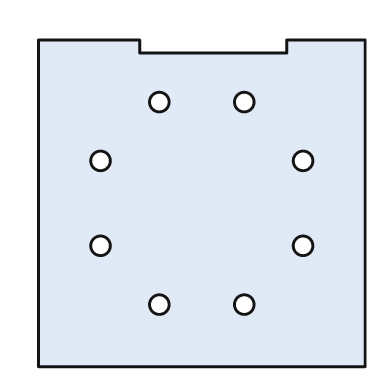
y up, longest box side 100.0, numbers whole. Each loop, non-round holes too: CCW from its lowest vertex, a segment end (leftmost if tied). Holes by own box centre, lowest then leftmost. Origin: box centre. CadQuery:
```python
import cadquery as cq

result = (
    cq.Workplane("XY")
    .moveTo(-50.0, -50.0)
    .lineTo(50.0, -50.0)
    .lineTo(50.0, 50.0)
    .lineTo(26.0, 50.0)
    .lineTo(26.0, 46.0)
    .lineTo(-19.0, 46.0)
    .lineTo(-19.0, 50.0)
    .lineTo(-50.0, 50.0)
    .close()
    .moveTo(-13.0, -31.0)
    .circle(3.0)
    .moveTo(13.0, -31.0)
    .circle(3.0)
    .moveTo(-31.0, -13.0)
    .circle(3.0)
    .moveTo(31.0, -13.0)
    .circle(3.0)
    .moveTo(-31.0, 13.0)
    .circle(3.0)
    .moveTo(31.0, 13.0)
    .circle(3.0)
    .moveTo(-13.0, 31.0)
    .circle(3.0)
    .moveTo(13.0, 31.0)
    .circle(3.0)
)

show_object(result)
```